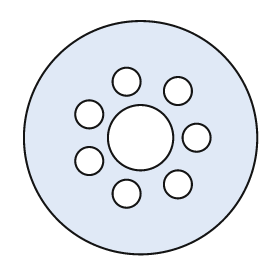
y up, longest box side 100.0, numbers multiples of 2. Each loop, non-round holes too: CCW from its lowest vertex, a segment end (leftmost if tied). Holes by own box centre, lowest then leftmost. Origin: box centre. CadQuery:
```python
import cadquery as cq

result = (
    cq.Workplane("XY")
    .moveTo(0.0, 0.0)
    .circle(50.0)
    .moveTo(-6.0, -24.0)
    .circle(6.0)
    .moveTo(16.0, -20.0)
    .circle(6.0)
    .moveTo(-22.0, -10.0)
    .circle(6.0)
    .moveTo(0.0, 0.0)
    .circle(14.0)
    .moveTo(24.0, 0.0)
    .circle(6.0)
    .moveTo(-22.0, 10.0)
    .circle(6.0)
    .moveTo(16.0, 20.0)
    .circle(6.0)
    .moveTo(-6.0, 24.0)
    .circle(6.0)
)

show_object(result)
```